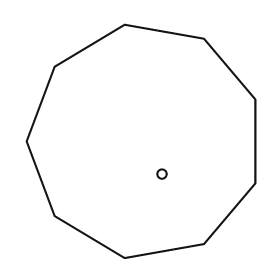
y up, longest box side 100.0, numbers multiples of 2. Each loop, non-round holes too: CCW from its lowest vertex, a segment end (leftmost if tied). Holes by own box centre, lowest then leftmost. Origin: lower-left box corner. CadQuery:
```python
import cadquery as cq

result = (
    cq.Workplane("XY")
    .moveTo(42.0, 0.0)
    .lineTo(76.0, 6.0)
    .lineTo(98.0, 32.0)
    .lineTo(98.0, 68.0)
    .lineTo(76.0, 94.0)
    .lineTo(42.0, 100.0)
    .lineTo(12.0, 82.0)
    .lineTo(0.0, 50.0)
    .lineTo(12.0, 18.0)
    .close()
    .moveTo(58.0, 36.0)
    .circle(2.0)
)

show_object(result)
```